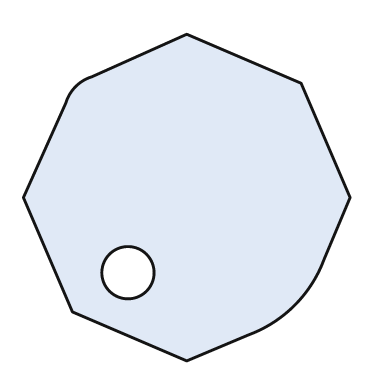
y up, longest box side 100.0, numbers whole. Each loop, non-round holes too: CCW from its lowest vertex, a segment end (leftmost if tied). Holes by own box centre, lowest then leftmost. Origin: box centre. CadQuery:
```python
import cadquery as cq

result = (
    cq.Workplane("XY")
    .moveTo(0.0, -50.0)
    .lineTo(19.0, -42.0)
    .threePointArc((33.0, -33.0), (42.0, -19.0))
    .lineTo(50.0, 0.0)
    .lineTo(35.0, 35.0)
    .lineTo(0.0, 50.0)
    .lineTo(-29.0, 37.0)
    .threePointArc((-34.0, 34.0), (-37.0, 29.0))
    .lineTo(-50.0, 0.0)
    .lineTo(-35.0, -35.0)
    .close()
    .moveTo(-18.0, -23.0)
    .circle(8.0)
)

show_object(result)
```